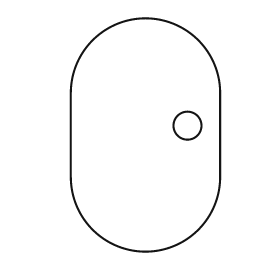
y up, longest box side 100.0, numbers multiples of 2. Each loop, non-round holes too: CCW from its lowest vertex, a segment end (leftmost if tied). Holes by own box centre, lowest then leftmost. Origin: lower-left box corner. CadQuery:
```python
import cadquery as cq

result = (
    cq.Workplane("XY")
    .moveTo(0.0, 32.0)
    .threePointArc((32.0, 0.0), (64.0, 32.0))
    .lineTo(64.0, 68.0)
    .threePointArc((32.0, 100.0), (0.0, 68.0))
    .close()
    .moveTo(50.0, 54.0)
    .circle(6.0)
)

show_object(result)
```